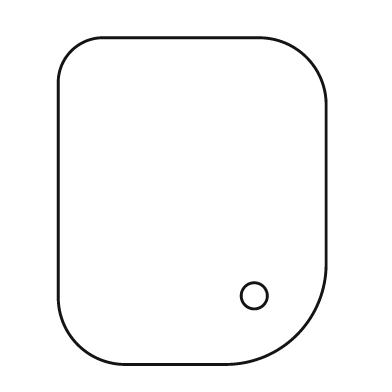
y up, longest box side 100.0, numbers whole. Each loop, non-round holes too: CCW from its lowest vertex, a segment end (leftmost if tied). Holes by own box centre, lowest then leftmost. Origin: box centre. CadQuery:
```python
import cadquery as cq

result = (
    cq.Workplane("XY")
    .moveTo(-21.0, -50.0)
    .lineTo(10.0, -50.0)
    .threePointArc((32.0, -41.0), (41.0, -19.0))
    .lineTo(41.0, 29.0)
    .threePointArc((35.0, 44.0), (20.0, 50.0))
    .lineTo(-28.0, 50.0)
    .threePointArc((-37.0, 46.0), (-41.0, 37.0))
    .lineTo(-41.0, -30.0)
    .threePointArc((-35.0, -44.0), (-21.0, -50.0))
    .close()
    .moveTo(19.0, -29.0)
    .circle(4.0)
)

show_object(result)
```